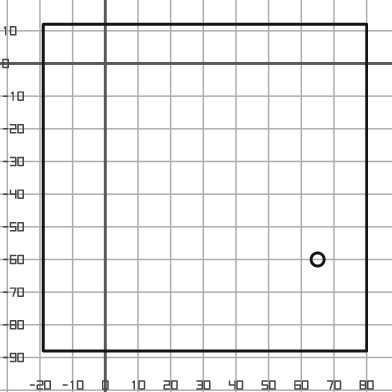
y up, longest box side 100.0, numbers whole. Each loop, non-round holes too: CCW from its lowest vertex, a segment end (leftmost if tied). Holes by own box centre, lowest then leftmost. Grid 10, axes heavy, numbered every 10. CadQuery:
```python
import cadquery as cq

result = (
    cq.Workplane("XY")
    .moveTo(-19.0, -88.0)
    .lineTo(80.0, -88.0)
    .lineTo(80.0, 12.0)
    .lineTo(-19.0, 12.0)
    .close()
    .moveTo(65.0, -60.0)
    .circle(2.0)
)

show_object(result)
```